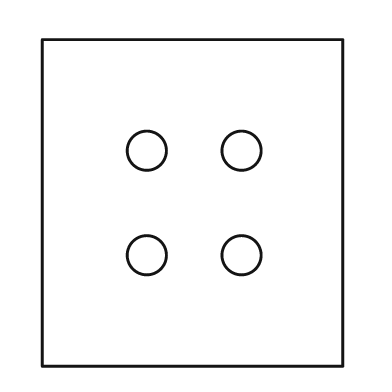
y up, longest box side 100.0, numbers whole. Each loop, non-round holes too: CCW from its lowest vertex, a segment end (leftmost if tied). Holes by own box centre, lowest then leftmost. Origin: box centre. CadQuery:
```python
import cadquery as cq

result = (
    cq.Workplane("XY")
    .moveTo(-46.0, -50.0)
    .lineTo(46.0, -50.0)
    .lineTo(46.0, 50.0)
    .lineTo(-46.0, 50.0)
    .close()
    .moveTo(-14.0, -16.0)
    .circle(6.0)
    .moveTo(15.0, -16.0)
    .circle(6.0)
    .moveTo(-14.0, 16.0)
    .circle(6.0)
    .moveTo(15.0, 16.0)
    .circle(6.0)
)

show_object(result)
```